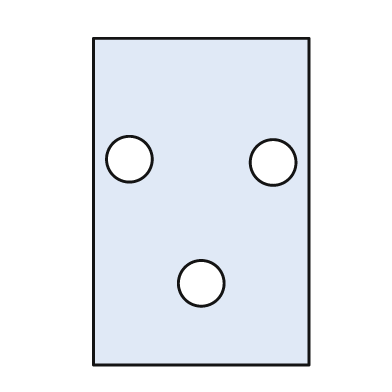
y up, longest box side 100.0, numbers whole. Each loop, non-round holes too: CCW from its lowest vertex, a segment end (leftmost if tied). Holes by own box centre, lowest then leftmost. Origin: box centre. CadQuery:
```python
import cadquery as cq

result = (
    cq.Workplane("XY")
    .moveTo(-33.0, -50.0)
    .lineTo(33.0, -50.0)
    .lineTo(33.0, 50.0)
    .lineTo(-33.0, 50.0)
    .close()
    .moveTo(0.0, -25.0)
    .circle(7.0)
    .moveTo(22.0, 12.0)
    .circle(7.0)
    .moveTo(-22.0, 13.0)
    .circle(7.0)
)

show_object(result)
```